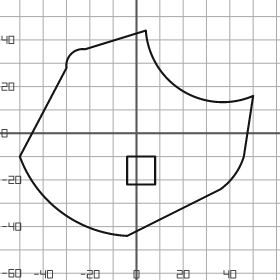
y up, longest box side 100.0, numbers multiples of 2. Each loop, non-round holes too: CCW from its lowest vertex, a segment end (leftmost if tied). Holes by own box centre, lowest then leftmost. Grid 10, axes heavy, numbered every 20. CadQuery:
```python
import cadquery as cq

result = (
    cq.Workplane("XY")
    .moveTo(-4.0, -44.0)
    .lineTo(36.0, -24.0)
    .threePointArc((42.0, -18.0), (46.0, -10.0))
    .lineTo(50.0, 16.0)
    .threePointArc((20.0, 18.0), (4.0, 44.0))
    .lineTo(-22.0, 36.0)
    .threePointArc((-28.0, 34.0), (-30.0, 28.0))
    .lineTo(-50.0, -10.0)
    .threePointArc((-32.0, -34.0), (-4.0, -44.0))
    .close()
    .moveTo(-4.0, -22.0)
    .lineTo(8.0, -22.0)
    .lineTo(8.0, -10.0)
    .lineTo(-4.0, -10.0)
    .close()
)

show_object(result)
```